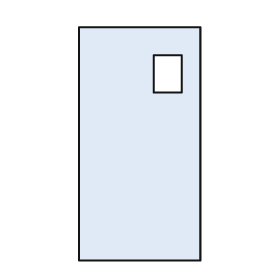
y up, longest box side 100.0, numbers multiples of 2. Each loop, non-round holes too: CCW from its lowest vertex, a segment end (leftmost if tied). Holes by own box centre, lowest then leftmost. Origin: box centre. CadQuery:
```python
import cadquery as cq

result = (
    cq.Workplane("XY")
    .moveTo(-26.0, -50.0)
    .lineTo(26.0, -50.0)
    .lineTo(26.0, 50.0)
    .lineTo(-26.0, 50.0)
    .close()
    .moveTo(6.0, 22.0)
    .lineTo(18.0, 22.0)
    .lineTo(18.0, 38.0)
    .lineTo(6.0, 38.0)
    .close()
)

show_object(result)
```